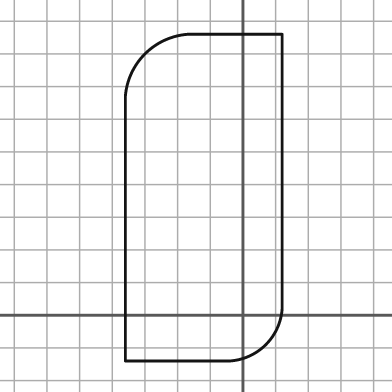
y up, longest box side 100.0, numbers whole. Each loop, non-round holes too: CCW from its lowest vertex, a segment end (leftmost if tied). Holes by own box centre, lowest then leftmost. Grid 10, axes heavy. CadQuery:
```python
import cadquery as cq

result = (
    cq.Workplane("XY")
    .moveTo(-36.0, -14.0)
    .lineTo(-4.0, -14.0)
    .threePointArc((7.0, -9.0), (12.0, 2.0))
    .lineTo(12.0, 86.0)
    .lineTo(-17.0, 86.0)
    .threePointArc((-30.0, 80.0), (-36.0, 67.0))
    .close()
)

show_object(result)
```